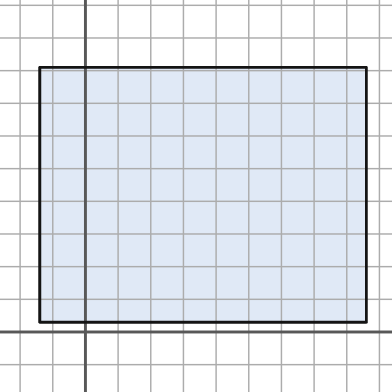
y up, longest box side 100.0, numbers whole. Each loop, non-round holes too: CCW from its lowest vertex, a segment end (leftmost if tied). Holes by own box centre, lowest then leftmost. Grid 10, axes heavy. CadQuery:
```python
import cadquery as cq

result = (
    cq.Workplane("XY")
    .moveTo(-14.0, 3.0)
    .lineTo(86.0, 3.0)
    .lineTo(86.0, 81.0)
    .lineTo(-14.0, 81.0)
    .close()
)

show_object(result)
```